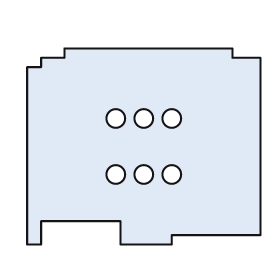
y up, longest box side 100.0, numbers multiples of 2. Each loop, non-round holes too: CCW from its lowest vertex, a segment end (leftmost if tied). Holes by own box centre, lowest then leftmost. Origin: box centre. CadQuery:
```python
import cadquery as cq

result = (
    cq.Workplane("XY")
    .moveTo(-50.0, -42.0)
    .lineTo(-44.0, -42.0)
    .lineTo(-44.0, -32.0)
    .lineTo(-10.0, -32.0)
    .lineTo(-10.0, -42.0)
    .lineTo(12.0, -42.0)
    .lineTo(12.0, -38.0)
    .lineTo(50.0, -38.0)
    .lineTo(50.0, 38.0)
    .lineTo(38.0, 38.0)
    .lineTo(38.0, 42.0)
    .lineTo(-34.0, 42.0)
    .lineTo(-34.0, 38.0)
    .lineTo(-44.0, 38.0)
    .lineTo(-44.0, 34.0)
    .lineTo(-50.0, 34.0)
    .close()
    .moveTo(-12.0, -12.0)
    .circle(4.0)
    .moveTo(0.0, -12.0)
    .circle(4.0)
    .moveTo(12.0, -12.0)
    .circle(4.0)
    .moveTo(-12.0, 12.0)
    .circle(4.0)
    .moveTo(0.0, 12.0)
    .circle(4.0)
    .moveTo(12.0, 12.0)
    .circle(4.0)
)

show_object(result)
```